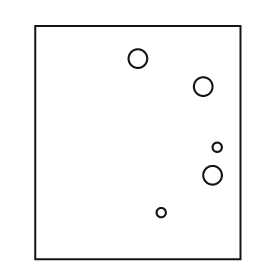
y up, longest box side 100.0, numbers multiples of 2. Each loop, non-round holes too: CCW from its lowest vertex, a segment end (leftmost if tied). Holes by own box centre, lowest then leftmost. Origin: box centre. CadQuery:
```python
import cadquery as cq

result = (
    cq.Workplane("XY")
    .moveTo(-44.0, -50.0)
    .lineTo(44.0, -50.0)
    .lineTo(44.0, 50.0)
    .lineTo(-44.0, 50.0)
    .close()
    .moveTo(10.0, -30.0)
    .circle(2.0)
    .moveTo(32.0, -14.0)
    .circle(4.0)
    .moveTo(34.0, -2.0)
    .circle(2.0)
    .moveTo(28.0, 24.0)
    .circle(4.0)
    .moveTo(0.0, 36.0)
    .circle(4.0)
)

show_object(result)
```